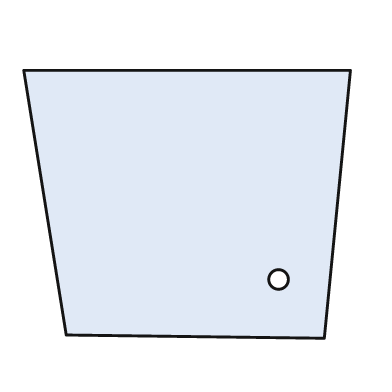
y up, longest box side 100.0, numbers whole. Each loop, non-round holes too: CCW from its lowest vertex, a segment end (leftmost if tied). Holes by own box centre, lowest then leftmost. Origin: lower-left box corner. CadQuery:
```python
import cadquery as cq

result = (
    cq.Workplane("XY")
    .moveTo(92.0, 0.0)
    .lineTo(100.0, 82.0)
    .lineTo(0.0, 82.0)
    .lineTo(13.0, 1.0)
    .close()
    .moveTo(78.0, 18.0)
    .circle(3.0)
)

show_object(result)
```